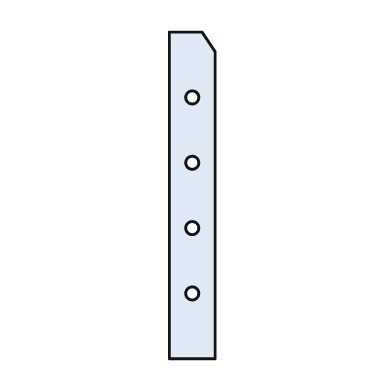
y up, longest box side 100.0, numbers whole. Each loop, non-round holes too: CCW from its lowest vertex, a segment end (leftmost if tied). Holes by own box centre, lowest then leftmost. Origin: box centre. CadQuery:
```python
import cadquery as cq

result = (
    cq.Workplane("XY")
    .moveTo(-7.0, -50.0)
    .lineTo(7.0, -50.0)
    .lineTo(7.0, 44.0)
    .lineTo(3.0, 50.0)
    .lineTo(-7.0, 50.0)
    .close()
    .moveTo(0.0, -30.0)
    .circle(2.0)
    .moveTo(0.0, -10.0)
    .circle(2.0)
    .moveTo(0.0, 10.0)
    .circle(2.0)
    .moveTo(0.0, 30.0)
    .circle(2.0)
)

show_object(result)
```